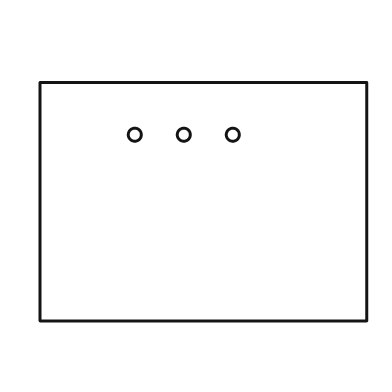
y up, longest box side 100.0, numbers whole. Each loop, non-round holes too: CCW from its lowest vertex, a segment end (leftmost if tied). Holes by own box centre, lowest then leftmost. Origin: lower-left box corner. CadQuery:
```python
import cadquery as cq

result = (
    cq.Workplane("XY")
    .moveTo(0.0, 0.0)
    .lineTo(100.0, 0.0)
    .lineTo(100.0, 73.0)
    .lineTo(0.0, 73.0)
    .close()
    .moveTo(29.0, 57.0)
    .circle(2.0)
    .moveTo(44.0, 57.0)
    .circle(2.0)
    .moveTo(59.0, 57.0)
    .circle(2.0)
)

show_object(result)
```